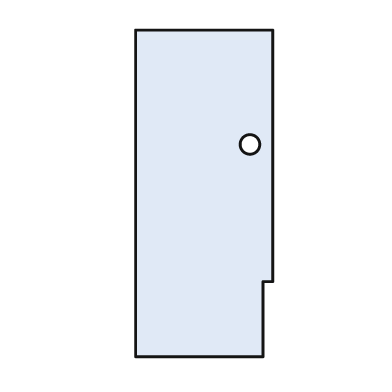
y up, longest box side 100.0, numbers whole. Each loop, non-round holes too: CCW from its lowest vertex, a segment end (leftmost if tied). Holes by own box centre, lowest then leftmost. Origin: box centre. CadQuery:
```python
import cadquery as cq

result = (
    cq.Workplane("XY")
    .moveTo(-21.0, -50.0)
    .lineTo(18.0, -50.0)
    .lineTo(18.0, -27.0)
    .lineTo(21.0, -27.0)
    .lineTo(21.0, 50.0)
    .lineTo(-21.0, 50.0)
    .close()
    .moveTo(14.0, 15.0)
    .circle(3.0)
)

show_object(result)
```